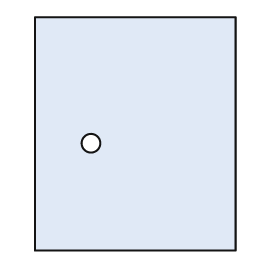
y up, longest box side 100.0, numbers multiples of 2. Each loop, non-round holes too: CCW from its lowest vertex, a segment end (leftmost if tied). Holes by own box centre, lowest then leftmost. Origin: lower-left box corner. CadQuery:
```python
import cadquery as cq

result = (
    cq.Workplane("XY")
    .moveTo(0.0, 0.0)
    .lineTo(86.0, 0.0)
    .lineTo(86.0, 100.0)
    .lineTo(0.0, 100.0)
    .close()
    .moveTo(24.0, 46.0)
    .circle(4.0)
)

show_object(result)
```